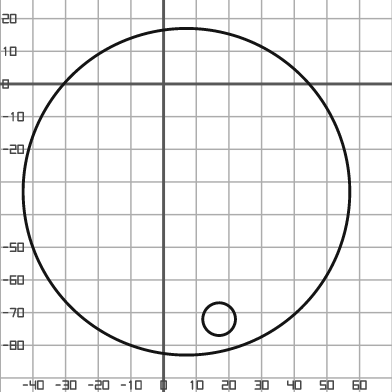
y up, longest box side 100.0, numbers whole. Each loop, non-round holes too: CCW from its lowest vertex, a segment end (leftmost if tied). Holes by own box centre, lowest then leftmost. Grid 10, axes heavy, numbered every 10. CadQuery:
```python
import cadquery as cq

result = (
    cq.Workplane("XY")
    .moveTo(7.0, -33.0)
    .circle(50.0)
    .moveTo(17.0, -72.0)
    .circle(5.0)
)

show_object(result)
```